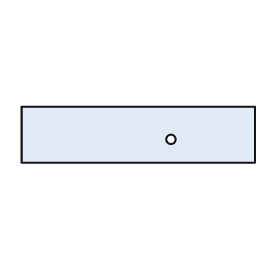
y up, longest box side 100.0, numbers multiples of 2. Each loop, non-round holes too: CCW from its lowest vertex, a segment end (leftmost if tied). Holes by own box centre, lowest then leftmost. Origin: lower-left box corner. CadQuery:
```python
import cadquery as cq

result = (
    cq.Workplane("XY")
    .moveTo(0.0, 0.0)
    .lineTo(100.0, 0.0)
    .lineTo(100.0, 24.0)
    .lineTo(0.0, 24.0)
    .close()
    .moveTo(64.0, 10.0)
    .circle(2.0)
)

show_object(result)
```